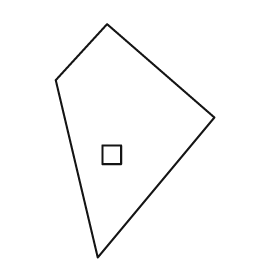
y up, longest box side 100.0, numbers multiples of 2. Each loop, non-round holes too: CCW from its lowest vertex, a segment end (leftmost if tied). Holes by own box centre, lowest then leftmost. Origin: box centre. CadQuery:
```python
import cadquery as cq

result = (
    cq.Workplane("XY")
    .moveTo(-16.0, -50.0)
    .lineTo(34.0, 10.0)
    .lineTo(-12.0, 50.0)
    .lineTo(-34.0, 26.0)
    .close()
    .moveTo(-14.0, -10.0)
    .lineTo(-6.0, -10.0)
    .lineTo(-6.0, -2.0)
    .lineTo(-14.0, -2.0)
    .close()
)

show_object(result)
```